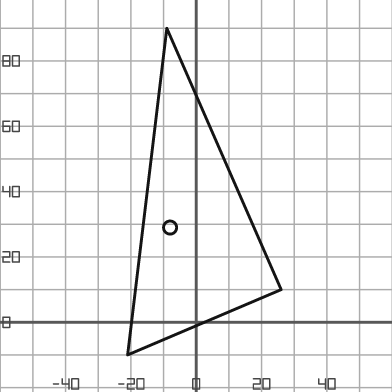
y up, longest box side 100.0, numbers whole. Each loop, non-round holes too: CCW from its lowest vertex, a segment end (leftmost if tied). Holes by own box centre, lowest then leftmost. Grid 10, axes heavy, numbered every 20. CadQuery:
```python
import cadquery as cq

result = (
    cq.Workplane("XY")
    .moveTo(-21.0, -10.0)
    .lineTo(26.0, 10.0)
    .lineTo(-9.0, 90.0)
    .close()
    .moveTo(-8.0, 29.0)
    .circle(2.0)
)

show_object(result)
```